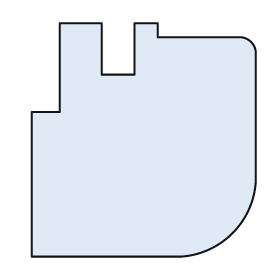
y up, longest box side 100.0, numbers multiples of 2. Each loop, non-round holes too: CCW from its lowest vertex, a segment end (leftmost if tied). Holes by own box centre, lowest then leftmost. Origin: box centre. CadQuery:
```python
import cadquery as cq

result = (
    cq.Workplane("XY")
    .moveTo(-48.0, -50.0)
    .lineTo(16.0, -50.0)
    .threePointArc((38.0, -40.0), (48.0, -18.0))
    .lineTo(48.0, 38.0)
    .threePointArc((46.0, 42.0), (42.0, 44.0))
    .lineTo(6.0, 44.0)
    .lineTo(6.0, 50.0)
    .lineTo(-4.0, 50.0)
    .lineTo(-4.0, 28.0)
    .lineTo(-18.0, 28.0)
    .lineTo(-18.0, 50.0)
    .lineTo(-36.0, 50.0)
    .lineTo(-36.0, 12.0)
    .lineTo(-48.0, 12.0)
    .close()
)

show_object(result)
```